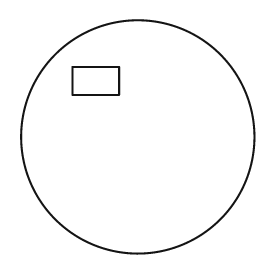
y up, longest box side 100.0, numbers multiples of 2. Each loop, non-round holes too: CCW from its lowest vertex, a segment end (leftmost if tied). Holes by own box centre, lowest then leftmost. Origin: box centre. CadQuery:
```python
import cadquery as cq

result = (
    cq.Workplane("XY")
    .moveTo(0.0, 0.0)
    .circle(50.0)
    .moveTo(-28.0, 18.0)
    .lineTo(-8.0, 18.0)
    .lineTo(-8.0, 30.0)
    .lineTo(-28.0, 30.0)
    .close()
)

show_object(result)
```